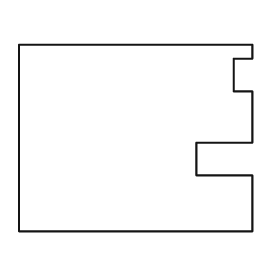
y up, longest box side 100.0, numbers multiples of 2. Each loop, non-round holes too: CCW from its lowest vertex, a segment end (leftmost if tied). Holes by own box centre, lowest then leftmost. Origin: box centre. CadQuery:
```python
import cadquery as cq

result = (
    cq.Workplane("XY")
    .moveTo(-50.0, -40.0)
    .lineTo(50.0, -40.0)
    .lineTo(50.0, -16.0)
    .lineTo(26.0, -16.0)
    .lineTo(26.0, -2.0)
    .lineTo(50.0, -2.0)
    .lineTo(50.0, 20.0)
    .lineTo(42.0, 20.0)
    .lineTo(42.0, 34.0)
    .lineTo(50.0, 34.0)
    .lineTo(50.0, 40.0)
    .lineTo(-50.0, 40.0)
    .close()
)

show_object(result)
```